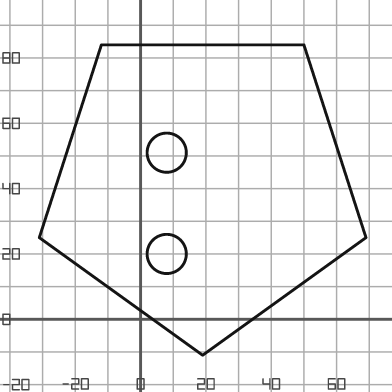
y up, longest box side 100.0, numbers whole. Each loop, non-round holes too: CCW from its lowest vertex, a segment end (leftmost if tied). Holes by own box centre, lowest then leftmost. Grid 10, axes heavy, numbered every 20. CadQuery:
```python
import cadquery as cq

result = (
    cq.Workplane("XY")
    .moveTo(19.0, -11.0)
    .lineTo(69.0, 25.0)
    .lineTo(50.0, 84.0)
    .lineTo(-12.0, 84.0)
    .lineTo(-31.0, 25.0)
    .close()
    .moveTo(8.0, 20.0)
    .circle(6.0)
    .moveTo(8.0, 51.0)
    .circle(6.0)
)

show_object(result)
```